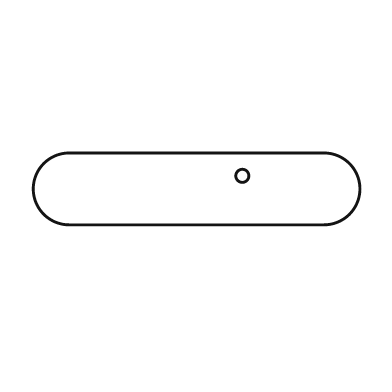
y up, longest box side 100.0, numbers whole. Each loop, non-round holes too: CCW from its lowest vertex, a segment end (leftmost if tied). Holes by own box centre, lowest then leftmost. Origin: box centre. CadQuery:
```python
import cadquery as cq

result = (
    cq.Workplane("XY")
    .moveTo(-39.0, -11.0)
    .lineTo(39.0, -11.0)
    .threePointArc((50.0, 0.0), (39.0, 11.0))
    .lineTo(-39.0, 11.0)
    .threePointArc((-50.0, 0.0), (-39.0, -11.0))
    .close()
    .moveTo(14.0, 4.0)
    .circle(2.0)
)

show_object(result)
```